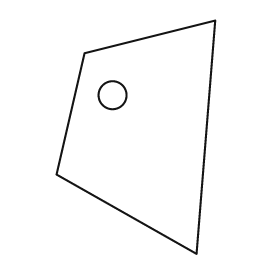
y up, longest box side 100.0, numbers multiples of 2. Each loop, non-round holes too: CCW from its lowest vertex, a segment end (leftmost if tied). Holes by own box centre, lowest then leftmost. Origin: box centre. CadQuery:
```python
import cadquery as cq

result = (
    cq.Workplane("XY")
    .moveTo(26.0, -50.0)
    .lineTo(34.0, 50.0)
    .lineTo(-22.0, 36.0)
    .lineTo(-34.0, -16.0)
    .close()
    .moveTo(-10.0, 18.0)
    .circle(6.0)
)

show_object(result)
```